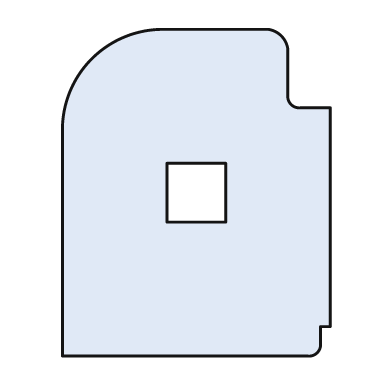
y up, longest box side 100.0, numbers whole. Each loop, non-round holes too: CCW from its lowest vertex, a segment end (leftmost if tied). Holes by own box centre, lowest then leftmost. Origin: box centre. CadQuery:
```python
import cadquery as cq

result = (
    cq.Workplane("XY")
    .moveTo(-41.0, -50.0)
    .lineTo(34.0, -50.0)
    .threePointArc((37.0, -49.0), (38.0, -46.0))
    .lineTo(38.0, -41.0)
    .lineTo(41.0, -41.0)
    .lineTo(41.0, 26.0)
    .lineTo(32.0, 26.0)
    .threePointArc((29.0, 27.0), (28.0, 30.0))
    .lineTo(28.0, 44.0)
    .threePointArc((26.0, 48.0), (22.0, 50.0))
    .lineTo(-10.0, 50.0)
    .threePointArc((-32.0, 41.0), (-41.0, 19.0))
    .close()
    .moveTo(-9.0, -9.0)
    .lineTo(9.0, -9.0)
    .lineTo(9.0, 9.0)
    .lineTo(-9.0, 9.0)
    .close()
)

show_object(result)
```